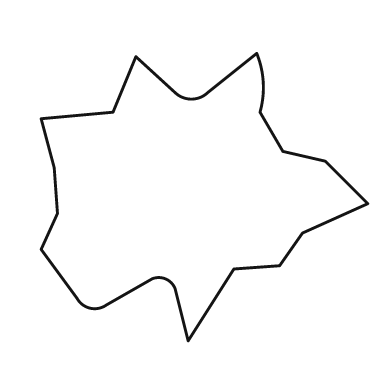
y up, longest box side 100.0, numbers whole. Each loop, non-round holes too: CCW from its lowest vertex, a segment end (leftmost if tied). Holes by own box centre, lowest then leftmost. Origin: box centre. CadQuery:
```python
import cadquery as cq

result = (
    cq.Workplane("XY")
    .moveTo(-5.0, -44.0)
    .lineTo(9.0, -22.0)
    .lineTo(23.0, -21.0)
    .lineTo(30.0, -11.0)
    .lineTo(50.0, -2.0)
    .lineTo(37.0, 11.0)
    .lineTo(24.0, 14.0)
    .lineTo(17.0, 26.0)
    .threePointArc((18.0, 35.0), (16.0, 44.0))
    .lineTo(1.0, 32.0)
    .threePointArc((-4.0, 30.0), (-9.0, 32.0))
    .lineTo(-21.0, 43.0)
    .lineTo(-28.0, 26.0)
    .lineTo(-50.0, 24.0)
    .lineTo(-46.0, 9.0)
    .lineTo(-45.0, -5.0)
    .lineTo(-50.0, -16.0)
    .lineTo(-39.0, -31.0)
    .threePointArc((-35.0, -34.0), (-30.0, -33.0))
    .lineTo(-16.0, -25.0)
    .threePointArc((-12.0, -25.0), (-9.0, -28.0))
    .close()
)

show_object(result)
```